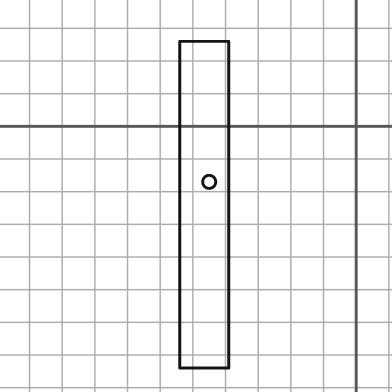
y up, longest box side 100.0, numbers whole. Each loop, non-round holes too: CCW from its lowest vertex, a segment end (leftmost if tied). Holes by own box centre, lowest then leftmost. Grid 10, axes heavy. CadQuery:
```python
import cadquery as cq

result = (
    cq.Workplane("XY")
    .moveTo(-54.0, -74.0)
    .lineTo(-39.0, -74.0)
    .lineTo(-39.0, 26.0)
    .lineTo(-54.0, 26.0)
    .close()
    .moveTo(-45.0, -17.0)
    .circle(2.0)
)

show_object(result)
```